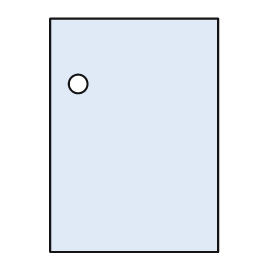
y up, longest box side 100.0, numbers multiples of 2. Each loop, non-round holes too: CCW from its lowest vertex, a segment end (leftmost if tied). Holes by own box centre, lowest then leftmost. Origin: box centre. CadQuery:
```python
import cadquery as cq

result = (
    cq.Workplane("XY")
    .moveTo(-36.0, -50.0)
    .lineTo(36.0, -50.0)
    .lineTo(36.0, 50.0)
    .lineTo(-36.0, 50.0)
    .close()
    .moveTo(-24.0, 22.0)
    .circle(4.0)
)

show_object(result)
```